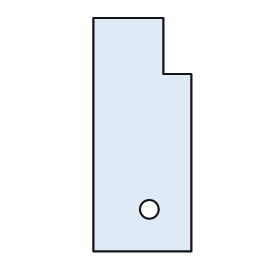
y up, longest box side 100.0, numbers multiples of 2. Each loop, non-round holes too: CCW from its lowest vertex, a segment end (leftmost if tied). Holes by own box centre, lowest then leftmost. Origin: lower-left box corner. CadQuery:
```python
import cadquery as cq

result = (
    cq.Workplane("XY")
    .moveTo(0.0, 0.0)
    .lineTo(42.0, 0.0)
    .lineTo(42.0, 76.0)
    .lineTo(30.0, 76.0)
    .lineTo(30.0, 100.0)
    .lineTo(0.0, 100.0)
    .close()
    .moveTo(24.0, 18.0)
    .circle(4.0)
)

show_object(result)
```